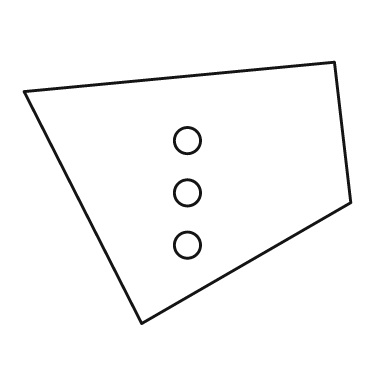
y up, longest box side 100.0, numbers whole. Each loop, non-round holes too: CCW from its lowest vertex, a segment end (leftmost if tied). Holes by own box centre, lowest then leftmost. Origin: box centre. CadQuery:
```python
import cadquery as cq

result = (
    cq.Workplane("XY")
    .moveTo(-14.0, -40.0)
    .lineTo(50.0, -3.0)
    .lineTo(45.0, 40.0)
    .lineTo(-50.0, 31.0)
    .close()
    .moveTo(0.0, -16.0)
    .circle(4.0)
    .moveTo(0.0, 0.0)
    .circle(4.0)
    .moveTo(0.0, 16.0)
    .circle(4.0)
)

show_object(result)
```